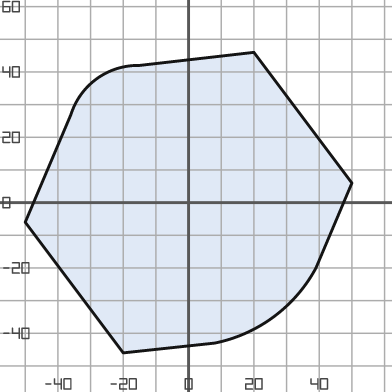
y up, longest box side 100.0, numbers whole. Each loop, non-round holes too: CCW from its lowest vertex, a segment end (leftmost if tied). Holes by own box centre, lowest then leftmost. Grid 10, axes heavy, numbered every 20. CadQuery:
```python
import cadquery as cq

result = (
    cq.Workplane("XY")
    .moveTo(-20.0, -46.0)
    .lineTo(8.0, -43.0)
    .threePointArc((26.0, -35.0), (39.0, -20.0))
    .lineTo(50.0, 6.0)
    .lineTo(20.0, 46.0)
    .lineTo(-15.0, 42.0)
    .threePointArc((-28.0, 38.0), (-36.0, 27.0))
    .lineTo(-50.0, -6.0)
    .close()
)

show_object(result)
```